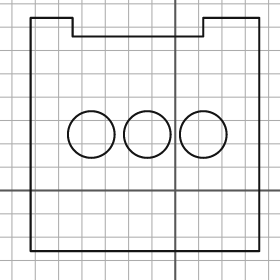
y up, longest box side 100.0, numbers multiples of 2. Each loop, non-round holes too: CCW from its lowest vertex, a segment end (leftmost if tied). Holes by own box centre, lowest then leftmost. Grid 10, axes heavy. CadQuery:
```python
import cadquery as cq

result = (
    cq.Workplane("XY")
    .moveTo(-62.0, -26.0)
    .lineTo(36.0, -26.0)
    .lineTo(36.0, 74.0)
    .lineTo(12.0, 74.0)
    .lineTo(12.0, 66.0)
    .lineTo(-44.0, 66.0)
    .lineTo(-44.0, 74.0)
    .lineTo(-62.0, 74.0)
    .close()
    .moveTo(-36.0, 24.0)
    .circle(10.0)
    .moveTo(-12.0, 24.0)
    .circle(10.0)
    .moveTo(12.0, 24.0)
    .circle(10.0)
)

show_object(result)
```